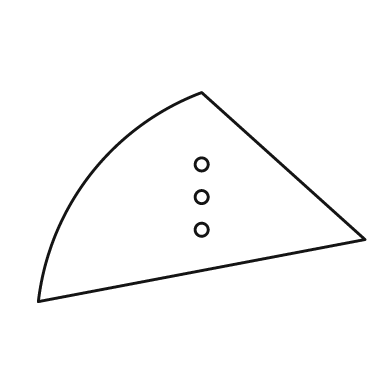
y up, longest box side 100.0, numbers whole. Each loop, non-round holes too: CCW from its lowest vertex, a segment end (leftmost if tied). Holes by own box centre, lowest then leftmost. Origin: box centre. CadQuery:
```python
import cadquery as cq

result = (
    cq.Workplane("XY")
    .moveTo(-50.0, -32.0)
    .lineTo(50.0, -13.0)
    .lineTo(0.0, 32.0)
    .threePointArc((-34.0, 7.0), (-50.0, -32.0))
    .close()
    .moveTo(0.0, -10.0)
    .circle(2.0)
    .moveTo(0.0, 0.0)
    .circle(2.0)
    .moveTo(0.0, 10.0)
    .circle(2.0)
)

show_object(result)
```